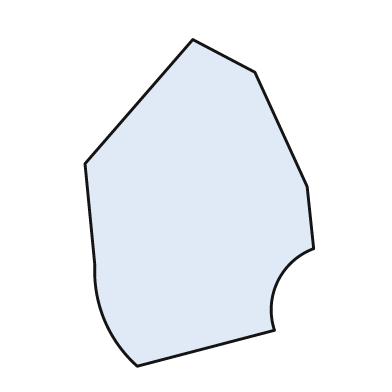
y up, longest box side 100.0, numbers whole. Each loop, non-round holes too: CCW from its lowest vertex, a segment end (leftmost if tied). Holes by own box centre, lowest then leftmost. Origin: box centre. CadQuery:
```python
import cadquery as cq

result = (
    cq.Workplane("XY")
    .moveTo(-19.0, -50.0)
    .lineTo(23.0, -39.0)
    .threePointArc((24.0, -24.0), (35.0, -14.0))
    .lineTo(33.0, 5.0)
    .lineTo(17.0, 40.0)
    .lineTo(-2.0, 50.0)
    .lineTo(-35.0, 12.0)
    .lineTo(-32.0, -19.0)
    .threePointArc((-29.0, -36.0), (-19.0, -50.0))
    .close()
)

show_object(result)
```